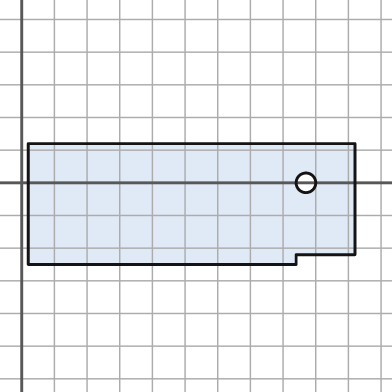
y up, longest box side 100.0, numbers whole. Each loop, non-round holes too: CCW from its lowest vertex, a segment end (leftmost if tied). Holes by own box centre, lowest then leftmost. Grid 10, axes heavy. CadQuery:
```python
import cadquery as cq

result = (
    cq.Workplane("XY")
    .moveTo(2.0, -25.0)
    .lineTo(84.0, -25.0)
    .lineTo(84.0, -22.0)
    .lineTo(102.0, -22.0)
    .lineTo(102.0, 12.0)
    .lineTo(2.0, 12.0)
    .close()
    .moveTo(87.0, 0.0)
    .circle(3.0)
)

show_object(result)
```